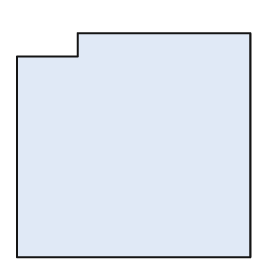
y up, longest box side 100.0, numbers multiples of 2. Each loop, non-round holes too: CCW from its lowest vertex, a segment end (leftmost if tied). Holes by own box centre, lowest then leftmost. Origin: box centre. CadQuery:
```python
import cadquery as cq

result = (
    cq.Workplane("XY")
    .moveTo(-50.0, -48.0)
    .lineTo(50.0, -48.0)
    .lineTo(50.0, 48.0)
    .lineTo(-24.0, 48.0)
    .lineTo(-24.0, 38.0)
    .lineTo(-50.0, 38.0)
    .close()
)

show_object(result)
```